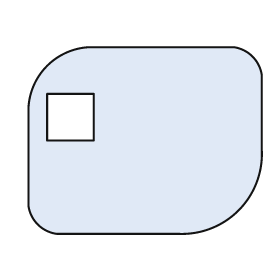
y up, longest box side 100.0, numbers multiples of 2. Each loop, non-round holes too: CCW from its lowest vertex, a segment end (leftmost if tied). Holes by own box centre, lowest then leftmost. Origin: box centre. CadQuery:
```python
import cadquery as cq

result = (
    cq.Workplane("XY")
    .moveTo(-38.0, -40.0)
    .lineTo(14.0, -40.0)
    .threePointArc((40.0, -30.0), (50.0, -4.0))
    .lineTo(50.0, 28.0)
    .threePointArc((46.0, 36.0), (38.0, 40.0))
    .lineTo(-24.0, 40.0)
    .threePointArc((-42.0, 32.0), (-50.0, 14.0))
    .lineTo(-50.0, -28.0)
    .threePointArc((-46.0, -36.0), (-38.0, -40.0))
    .close()
    .moveTo(-42.0, 0.0)
    .lineTo(-22.0, 0.0)
    .lineTo(-22.0, 20.0)
    .lineTo(-42.0, 20.0)
    .close()
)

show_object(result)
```